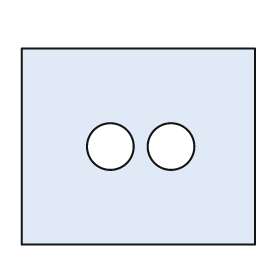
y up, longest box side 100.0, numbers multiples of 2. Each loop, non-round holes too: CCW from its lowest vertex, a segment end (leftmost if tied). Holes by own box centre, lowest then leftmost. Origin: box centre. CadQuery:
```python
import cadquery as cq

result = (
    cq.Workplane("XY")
    .moveTo(-50.0, -42.0)
    .lineTo(50.0, -42.0)
    .lineTo(50.0, 42.0)
    .lineTo(-50.0, 42.0)
    .close()
    .moveTo(-12.0, 0.0)
    .circle(10.0)
    .moveTo(14.0, 0.0)
    .circle(10.0)
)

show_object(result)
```